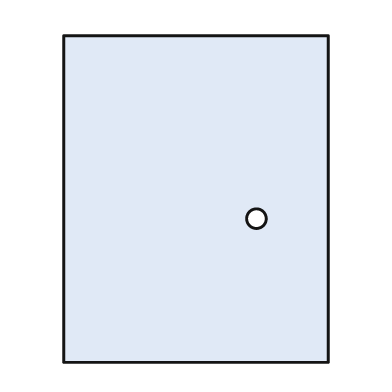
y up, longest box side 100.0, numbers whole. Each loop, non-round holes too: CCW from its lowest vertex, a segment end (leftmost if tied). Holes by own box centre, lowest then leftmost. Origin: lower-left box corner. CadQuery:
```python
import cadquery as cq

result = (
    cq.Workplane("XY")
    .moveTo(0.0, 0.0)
    .lineTo(81.0, 0.0)
    .lineTo(81.0, 100.0)
    .lineTo(0.0, 100.0)
    .close()
    .moveTo(59.0, 44.0)
    .circle(3.0)
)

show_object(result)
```